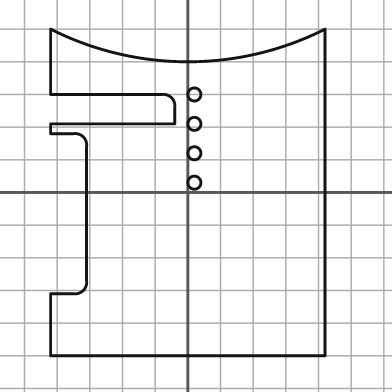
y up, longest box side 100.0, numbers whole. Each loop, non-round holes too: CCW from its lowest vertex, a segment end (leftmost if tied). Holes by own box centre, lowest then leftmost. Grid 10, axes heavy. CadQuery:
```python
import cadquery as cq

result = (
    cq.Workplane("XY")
    .moveTo(-42.0, -50.0)
    .lineTo(42.0, -50.0)
    .lineTo(42.0, 50.0)
    .threePointArc((0.0, 40.0), (-42.0, 50.0))
    .lineTo(-42.0, 30.0)
    .lineTo(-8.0, 30.0)
    .threePointArc((-5.0, 29.0), (-4.0, 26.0))
    .lineTo(-4.0, 21.0)
    .lineTo(-42.0, 21.0)
    .lineTo(-42.0, 18.0)
    .lineTo(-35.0, 18.0)
    .threePointArc((-32.0, 17.0), (-31.0, 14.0))
    .lineTo(-31.0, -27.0)
    .threePointArc((-32.0, -30.0), (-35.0, -31.0))
    .lineTo(-42.0, -31.0)
    .close()
    .moveTo(2.0, 3.0)
    .circle(2.0)
    .moveTo(2.0, 12.0)
    .circle(2.0)
    .moveTo(2.0, 21.0)
    .circle(2.0)
    .moveTo(2.0, 30.0)
    .circle(2.0)
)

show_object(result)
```